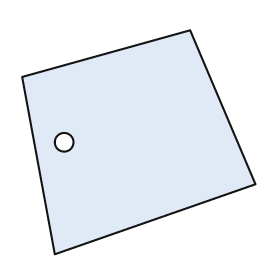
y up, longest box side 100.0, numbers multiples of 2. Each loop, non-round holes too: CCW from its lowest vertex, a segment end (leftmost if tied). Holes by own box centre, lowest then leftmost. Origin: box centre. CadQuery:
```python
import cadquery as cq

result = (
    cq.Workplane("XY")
    .moveTo(-36.0, -48.0)
    .lineTo(50.0, -18.0)
    .lineTo(22.0, 48.0)
    .lineTo(-50.0, 28.0)
    .close()
    .moveTo(-32.0, 0.0)
    .circle(4.0)
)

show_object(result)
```